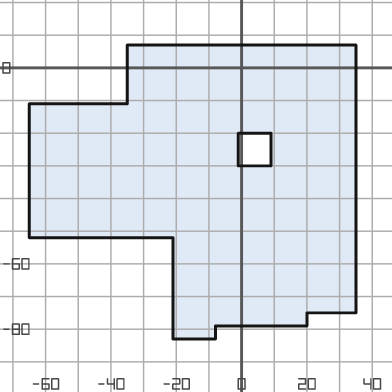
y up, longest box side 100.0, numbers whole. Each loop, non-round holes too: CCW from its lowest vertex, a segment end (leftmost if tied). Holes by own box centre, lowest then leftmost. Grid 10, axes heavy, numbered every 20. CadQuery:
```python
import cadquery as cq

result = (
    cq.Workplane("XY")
    .moveTo(-21.0, -83.0)
    .lineTo(-8.0, -83.0)
    .lineTo(-8.0, -79.0)
    .lineTo(20.0, -79.0)
    .lineTo(20.0, -75.0)
    .lineTo(35.0, -75.0)
    .lineTo(35.0, 7.0)
    .lineTo(-35.0, 7.0)
    .lineTo(-35.0, -11.0)
    .lineTo(-65.0, -11.0)
    .lineTo(-65.0, -52.0)
    .lineTo(-21.0, -52.0)
    .close()
    .moveTo(-1.0, -30.0)
    .lineTo(9.0, -30.0)
    .lineTo(9.0, -20.0)
    .lineTo(-1.0, -20.0)
    .close()
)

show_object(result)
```